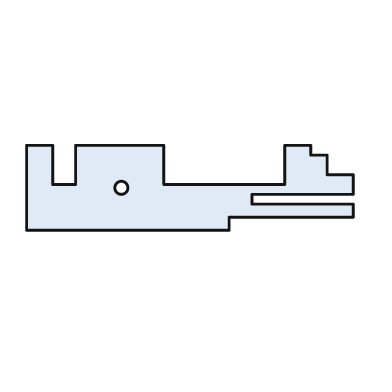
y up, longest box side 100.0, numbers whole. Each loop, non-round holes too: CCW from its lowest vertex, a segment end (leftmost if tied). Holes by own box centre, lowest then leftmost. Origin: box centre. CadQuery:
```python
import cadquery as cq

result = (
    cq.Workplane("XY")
    .moveTo(-50.0, -13.0)
    .lineTo(12.0, -13.0)
    .lineTo(12.0, -9.0)
    .lineTo(50.0, -9.0)
    .lineTo(50.0, -5.0)
    .lineTo(19.0, -5.0)
    .lineTo(19.0, -2.0)
    .lineTo(50.0, -2.0)
    .lineTo(50.0, 4.0)
    .lineTo(42.0, 4.0)
    .lineTo(42.0, 10.0)
    .lineTo(37.0, 10.0)
    .lineTo(37.0, 13.0)
    .lineTo(29.0, 13.0)
    .lineTo(29.0, 1.0)
    .lineTo(-8.0, 1.0)
    .lineTo(-8.0, 13.0)
    .lineTo(-35.0, 13.0)
    .lineTo(-35.0, 1.0)
    .lineTo(-42.0, 1.0)
    .lineTo(-42.0, 13.0)
    .lineTo(-50.0, 13.0)
    .close()
    .moveTo(-21.0, 0.0)
    .circle(2.0)
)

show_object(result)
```